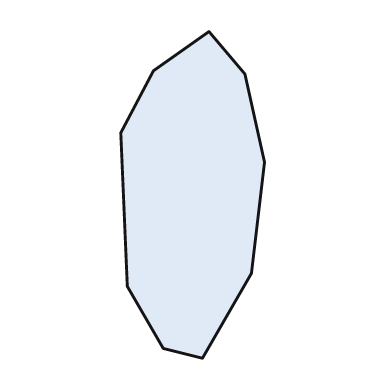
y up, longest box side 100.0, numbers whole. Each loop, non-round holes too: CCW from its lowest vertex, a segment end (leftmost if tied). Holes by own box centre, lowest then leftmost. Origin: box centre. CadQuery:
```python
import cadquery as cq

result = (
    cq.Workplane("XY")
    .moveTo(3.0, -50.0)
    .lineTo(18.0, -24.0)
    .lineTo(22.0, 10.0)
    .lineTo(16.0, 37.0)
    .lineTo(5.0, 50.0)
    .lineTo(-12.0, 38.0)
    .lineTo(-22.0, 19.0)
    .lineTo(-20.0, -28.0)
    .lineTo(-9.0, -47.0)
    .close()
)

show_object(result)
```